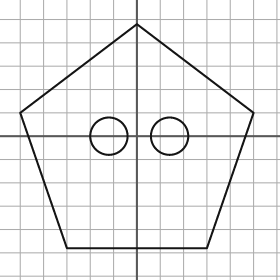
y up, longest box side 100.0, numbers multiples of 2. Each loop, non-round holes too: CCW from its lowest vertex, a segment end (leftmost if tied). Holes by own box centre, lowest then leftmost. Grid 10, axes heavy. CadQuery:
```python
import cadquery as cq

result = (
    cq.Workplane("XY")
    .moveTo(-30.0, -48.0)
    .lineTo(30.0, -48.0)
    .lineTo(50.0, 10.0)
    .lineTo(0.0, 48.0)
    .lineTo(-50.0, 10.0)
    .close()
    .moveTo(-12.0, 0.0)
    .circle(8.0)
    .moveTo(14.0, 0.0)
    .circle(8.0)
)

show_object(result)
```